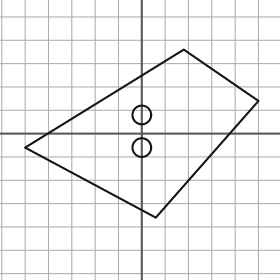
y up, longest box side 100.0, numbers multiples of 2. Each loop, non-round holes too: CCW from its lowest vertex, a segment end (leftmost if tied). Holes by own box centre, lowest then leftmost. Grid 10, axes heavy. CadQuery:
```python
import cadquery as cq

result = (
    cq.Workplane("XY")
    .moveTo(6.0, -36.0)
    .lineTo(50.0, 14.0)
    .lineTo(18.0, 36.0)
    .lineTo(-50.0, -6.0)
    .close()
    .moveTo(0.0, -6.0)
    .circle(4.0)
    .moveTo(0.0, 8.0)
    .circle(4.0)
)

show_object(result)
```